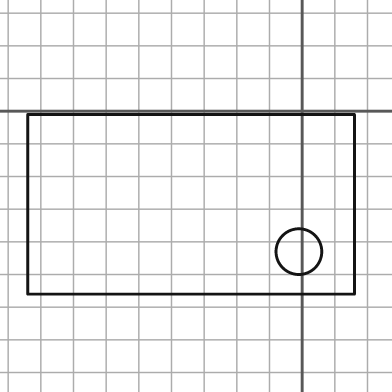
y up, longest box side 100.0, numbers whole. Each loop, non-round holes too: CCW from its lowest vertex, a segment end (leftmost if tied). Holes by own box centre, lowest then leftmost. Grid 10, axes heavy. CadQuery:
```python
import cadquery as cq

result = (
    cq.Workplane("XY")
    .moveTo(-84.0, -56.0)
    .lineTo(16.0, -56.0)
    .lineTo(16.0, -1.0)
    .lineTo(-84.0, -1.0)
    .close()
    .moveTo(-1.0, -43.0)
    .circle(7.0)
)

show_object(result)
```